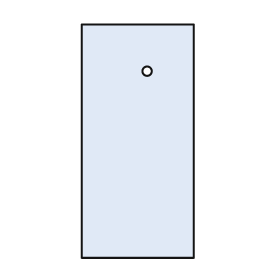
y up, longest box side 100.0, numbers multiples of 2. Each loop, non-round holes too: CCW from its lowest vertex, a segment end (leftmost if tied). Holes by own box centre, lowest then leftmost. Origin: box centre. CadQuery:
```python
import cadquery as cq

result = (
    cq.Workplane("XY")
    .moveTo(-24.0, -50.0)
    .lineTo(24.0, -50.0)
    .lineTo(24.0, 50.0)
    .lineTo(-24.0, 50.0)
    .close()
    .moveTo(4.0, 30.0)
    .circle(2.0)
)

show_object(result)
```